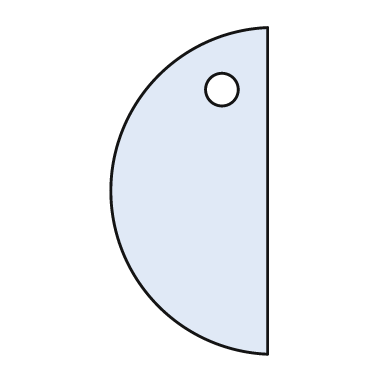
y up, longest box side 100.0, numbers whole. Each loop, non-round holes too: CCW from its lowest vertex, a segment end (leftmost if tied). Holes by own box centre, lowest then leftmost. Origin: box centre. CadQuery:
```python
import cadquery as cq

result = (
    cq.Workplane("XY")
    .moveTo(24.0, -50.0)
    .lineTo(24.0, 50.0)
    .threePointArc((-24.0, 0.0), (24.0, -50.0))
    .close()
    .moveTo(10.0, 31.0)
    .circle(5.0)
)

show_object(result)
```